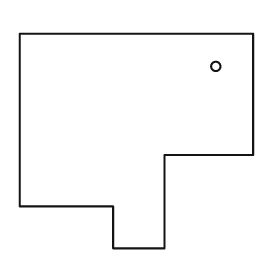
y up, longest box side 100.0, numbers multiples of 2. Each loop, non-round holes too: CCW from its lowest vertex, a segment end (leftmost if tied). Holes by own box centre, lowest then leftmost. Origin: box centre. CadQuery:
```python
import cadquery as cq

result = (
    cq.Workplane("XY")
    .moveTo(-10.0, -46.0)
    .lineTo(12.0, -46.0)
    .lineTo(12.0, -6.0)
    .lineTo(50.0, -6.0)
    .lineTo(50.0, 46.0)
    .lineTo(-50.0, 46.0)
    .lineTo(-50.0, -28.0)
    .lineTo(-10.0, -28.0)
    .close()
    .moveTo(34.0, 32.0)
    .circle(2.0)
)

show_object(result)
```